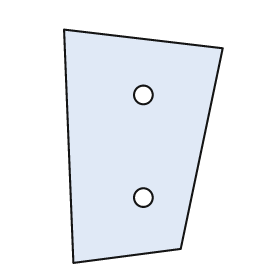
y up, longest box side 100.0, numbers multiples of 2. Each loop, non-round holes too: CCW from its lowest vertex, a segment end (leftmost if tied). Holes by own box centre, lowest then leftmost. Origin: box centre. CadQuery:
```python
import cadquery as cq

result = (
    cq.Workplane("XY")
    .moveTo(-30.0, -50.0)
    .lineTo(16.0, -44.0)
    .lineTo(34.0, 42.0)
    .lineTo(-34.0, 50.0)
    .close()
    .moveTo(0.0, -22.0)
    .circle(4.0)
    .moveTo(0.0, 22.0)
    .circle(4.0)
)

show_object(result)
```